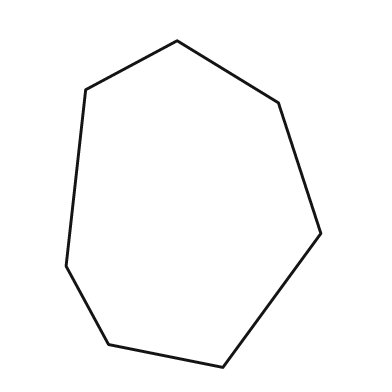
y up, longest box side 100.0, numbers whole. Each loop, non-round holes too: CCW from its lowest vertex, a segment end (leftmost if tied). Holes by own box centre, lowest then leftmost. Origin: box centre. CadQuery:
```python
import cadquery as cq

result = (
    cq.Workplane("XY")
    .moveTo(9.0, -50.0)
    .lineTo(39.0, -9.0)
    .lineTo(26.0, 31.0)
    .lineTo(-5.0, 50.0)
    .lineTo(-33.0, 35.0)
    .lineTo(-39.0, -19.0)
    .lineTo(-26.0, -43.0)
    .close()
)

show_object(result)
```